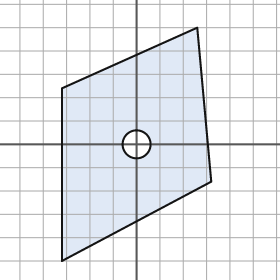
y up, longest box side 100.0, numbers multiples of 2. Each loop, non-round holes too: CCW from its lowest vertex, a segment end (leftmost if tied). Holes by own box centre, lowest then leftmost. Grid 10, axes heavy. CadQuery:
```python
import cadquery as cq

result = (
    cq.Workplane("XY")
    .moveTo(-32.0, -50.0)
    .lineTo(32.0, -16.0)
    .lineTo(26.0, 50.0)
    .lineTo(-32.0, 24.0)
    .close()
    .moveTo(0.0, 0.0)
    .circle(6.0)
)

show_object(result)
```